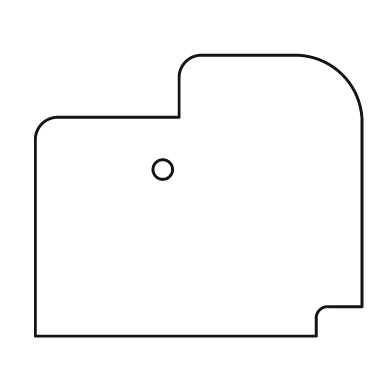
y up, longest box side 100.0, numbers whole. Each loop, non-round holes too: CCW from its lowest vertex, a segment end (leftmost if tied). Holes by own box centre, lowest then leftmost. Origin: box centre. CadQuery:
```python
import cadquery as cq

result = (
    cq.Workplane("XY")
    .moveTo(-50.0, -43.0)
    .lineTo(36.0, -43.0)
    .lineTo(36.0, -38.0)
    .threePointArc((37.0, -35.0), (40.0, -34.0))
    .lineTo(50.0, -34.0)
    .lineTo(50.0, 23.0)
    .threePointArc((44.0, 37.0), (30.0, 43.0))
    .lineTo(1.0, 43.0)
    .threePointArc((-4.0, 41.0), (-6.0, 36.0))
    .lineTo(-6.0, 24.0)
    .lineTo(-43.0, 24.0)
    .threePointArc((-48.0, 22.0), (-50.0, 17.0))
    .close()
    .moveTo(-11.0, 8.0)
    .circle(3.0)
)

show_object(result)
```